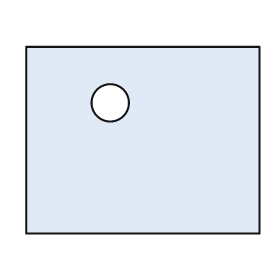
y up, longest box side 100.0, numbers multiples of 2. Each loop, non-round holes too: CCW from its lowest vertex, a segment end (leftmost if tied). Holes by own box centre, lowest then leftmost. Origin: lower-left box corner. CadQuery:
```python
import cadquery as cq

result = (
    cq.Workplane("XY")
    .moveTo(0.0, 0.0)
    .lineTo(100.0, 0.0)
    .lineTo(100.0, 80.0)
    .lineTo(0.0, 80.0)
    .close()
    .moveTo(36.0, 56.0)
    .circle(8.0)
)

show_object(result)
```